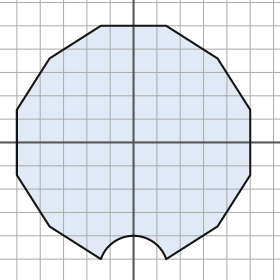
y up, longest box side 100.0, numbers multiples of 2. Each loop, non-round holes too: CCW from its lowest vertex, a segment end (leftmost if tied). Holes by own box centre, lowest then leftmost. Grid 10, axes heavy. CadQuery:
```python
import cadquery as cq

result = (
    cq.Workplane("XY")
    .moveTo(-14.0, -50.0)
    .threePointArc((0.0, -40.0), (14.0, -50.0))
    .lineTo(36.0, -36.0)
    .lineTo(50.0, -14.0)
    .lineTo(50.0, 14.0)
    .lineTo(36.0, 36.0)
    .lineTo(14.0, 50.0)
    .lineTo(-14.0, 50.0)
    .lineTo(-36.0, 36.0)
    .lineTo(-50.0, 14.0)
    .lineTo(-50.0, -14.0)
    .lineTo(-36.0, -36.0)
    .close()
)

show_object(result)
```